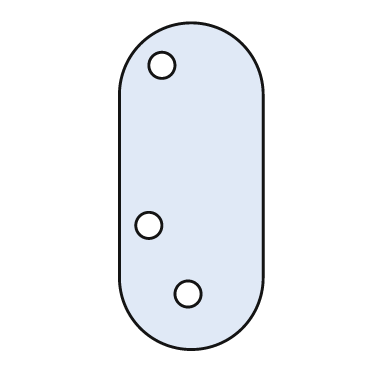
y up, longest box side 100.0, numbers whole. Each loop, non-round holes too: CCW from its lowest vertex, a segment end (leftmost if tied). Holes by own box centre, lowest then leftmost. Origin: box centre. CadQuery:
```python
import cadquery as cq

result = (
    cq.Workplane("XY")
    .moveTo(-22.0, -28.0)
    .threePointArc((0.0, -50.0), (22.0, -28.0))
    .lineTo(22.0, 28.0)
    .threePointArc((0.0, 50.0), (-22.0, 28.0))
    .close()
    .moveTo(-1.0, -33.0)
    .circle(4.0)
    .moveTo(-13.0, -12.0)
    .circle(4.0)
    .moveTo(-9.0, 37.0)
    .circle(4.0)
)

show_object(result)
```